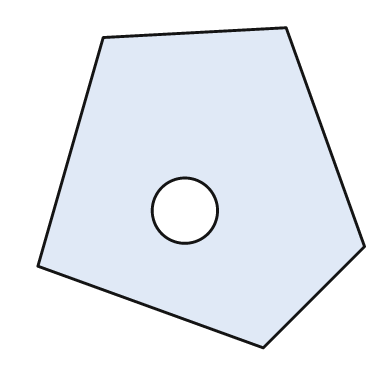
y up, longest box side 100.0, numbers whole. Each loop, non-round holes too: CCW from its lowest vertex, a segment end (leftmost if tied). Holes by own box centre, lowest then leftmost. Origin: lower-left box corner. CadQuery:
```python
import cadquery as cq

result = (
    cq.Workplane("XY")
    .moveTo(69.0, 0.0)
    .lineTo(100.0, 31.0)
    .lineTo(76.0, 98.0)
    .lineTo(20.0, 95.0)
    .lineTo(0.0, 25.0)
    .close()
    .moveTo(45.0, 42.0)
    .circle(10.0)
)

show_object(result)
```